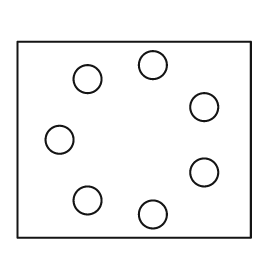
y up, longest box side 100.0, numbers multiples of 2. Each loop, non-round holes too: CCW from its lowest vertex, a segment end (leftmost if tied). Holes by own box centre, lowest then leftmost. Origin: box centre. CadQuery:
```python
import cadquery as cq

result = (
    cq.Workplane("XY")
    .moveTo(-50.0, -42.0)
    .lineTo(50.0, -42.0)
    .lineTo(50.0, 42.0)
    .lineTo(-50.0, 42.0)
    .close()
    .moveTo(8.0, -32.0)
    .circle(6.0)
    .moveTo(-20.0, -26.0)
    .circle(6.0)
    .moveTo(30.0, -14.0)
    .circle(6.0)
    .moveTo(-32.0, 0.0)
    .circle(6.0)
    .moveTo(30.0, 14.0)
    .circle(6.0)
    .moveTo(-20.0, 26.0)
    .circle(6.0)
    .moveTo(8.0, 32.0)
    .circle(6.0)
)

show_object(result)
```